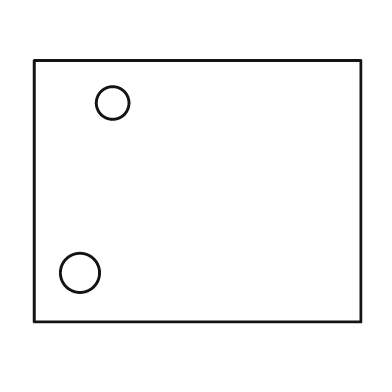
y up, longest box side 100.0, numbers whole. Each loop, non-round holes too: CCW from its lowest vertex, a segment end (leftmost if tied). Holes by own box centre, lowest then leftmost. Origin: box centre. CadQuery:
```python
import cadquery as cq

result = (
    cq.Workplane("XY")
    .moveTo(-50.0, -40.0)
    .lineTo(50.0, -40.0)
    .lineTo(50.0, 40.0)
    .lineTo(-50.0, 40.0)
    .close()
    .moveTo(-36.0, -25.0)
    .circle(6.0)
    .moveTo(-26.0, 27.0)
    .circle(5.0)
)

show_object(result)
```